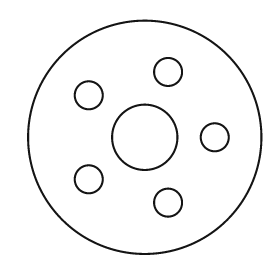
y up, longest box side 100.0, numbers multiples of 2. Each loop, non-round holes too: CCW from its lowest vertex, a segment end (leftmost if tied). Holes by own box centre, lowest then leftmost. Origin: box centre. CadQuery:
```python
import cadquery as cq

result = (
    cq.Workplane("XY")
    .moveTo(0.0, 0.0)
    .circle(50.0)
    .moveTo(10.0, -28.0)
    .circle(6.0)
    .moveTo(-24.0, -18.0)
    .circle(6.0)
    .moveTo(0.0, 0.0)
    .circle(14.0)
    .moveTo(30.0, 0.0)
    .circle(6.0)
    .moveTo(-24.0, 18.0)
    .circle(6.0)
    .moveTo(10.0, 28.0)
    .circle(6.0)
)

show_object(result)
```